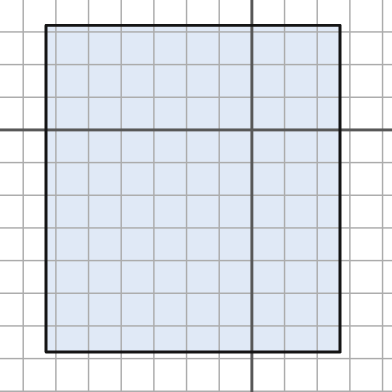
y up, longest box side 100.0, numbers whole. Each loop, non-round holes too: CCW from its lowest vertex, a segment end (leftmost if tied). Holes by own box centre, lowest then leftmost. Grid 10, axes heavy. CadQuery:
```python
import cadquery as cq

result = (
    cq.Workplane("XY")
    .moveTo(-63.0, -68.0)
    .lineTo(27.0, -68.0)
    .lineTo(27.0, 32.0)
    .lineTo(-63.0, 32.0)
    .close()
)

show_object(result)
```